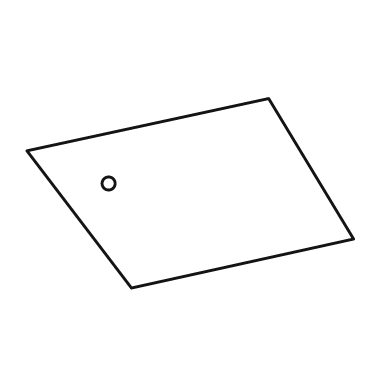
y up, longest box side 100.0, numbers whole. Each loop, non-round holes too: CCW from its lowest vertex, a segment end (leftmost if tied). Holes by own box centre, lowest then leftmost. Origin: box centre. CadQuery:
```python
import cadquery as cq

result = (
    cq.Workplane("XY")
    .moveTo(-18.0, -29.0)
    .lineTo(50.0, -14.0)
    .lineTo(24.0, 29.0)
    .lineTo(-50.0, 13.0)
    .close()
    .moveTo(-25.0, 3.0)
    .circle(2.0)
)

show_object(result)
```